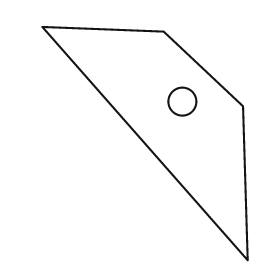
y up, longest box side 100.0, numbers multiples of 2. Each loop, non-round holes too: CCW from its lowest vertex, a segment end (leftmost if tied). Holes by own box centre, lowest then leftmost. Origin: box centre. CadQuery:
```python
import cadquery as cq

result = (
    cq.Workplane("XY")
    .moveTo(44.0, -50.0)
    .lineTo(42.0, 16.0)
    .lineTo(8.0, 48.0)
    .lineTo(-44.0, 50.0)
    .close()
    .moveTo(16.0, 18.0)
    .circle(6.0)
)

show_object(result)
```